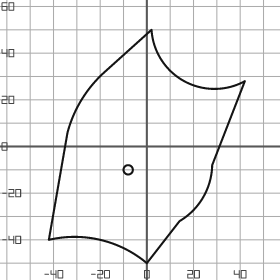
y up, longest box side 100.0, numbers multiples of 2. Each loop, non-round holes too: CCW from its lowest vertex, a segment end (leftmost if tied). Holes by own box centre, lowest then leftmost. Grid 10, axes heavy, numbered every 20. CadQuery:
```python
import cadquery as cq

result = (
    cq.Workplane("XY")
    .moveTo(0.0, -50.0)
    .lineTo(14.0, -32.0)
    .threePointArc((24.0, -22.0), (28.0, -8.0))
    .lineTo(42.0, 28.0)
    .threePointArc((16.0, 28.0), (2.0, 50.0))
    .lineTo(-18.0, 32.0)
    .threePointArc((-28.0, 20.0), (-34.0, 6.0))
    .lineTo(-42.0, -40.0)
    .threePointArc((-20.0, -40.0), (0.0, -50.0))
    .close()
    .moveTo(-8.0, -10.0)
    .circle(2.0)
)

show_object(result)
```